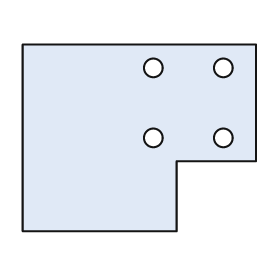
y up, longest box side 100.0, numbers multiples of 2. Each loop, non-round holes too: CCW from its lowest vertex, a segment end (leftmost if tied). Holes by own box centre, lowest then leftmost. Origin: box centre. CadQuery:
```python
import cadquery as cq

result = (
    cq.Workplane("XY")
    .moveTo(-50.0, -40.0)
    .lineTo(16.0, -40.0)
    .lineTo(16.0, -10.0)
    .lineTo(50.0, -10.0)
    .lineTo(50.0, 40.0)
    .lineTo(-50.0, 40.0)
    .close()
    .moveTo(6.0, 0.0)
    .circle(4.0)
    .moveTo(36.0, 0.0)
    .circle(4.0)
    .moveTo(6.0, 30.0)
    .circle(4.0)
    .moveTo(36.0, 30.0)
    .circle(4.0)
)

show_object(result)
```